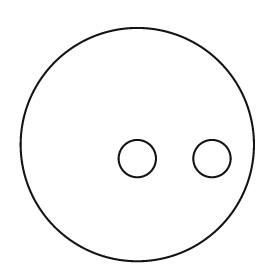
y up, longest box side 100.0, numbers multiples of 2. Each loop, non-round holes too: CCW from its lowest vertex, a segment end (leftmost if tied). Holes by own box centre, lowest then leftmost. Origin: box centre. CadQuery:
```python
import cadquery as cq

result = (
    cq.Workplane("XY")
    .moveTo(0.0, 0.0)
    .circle(50.0)
    .moveTo(0.0, -6.0)
    .circle(8.0)
    .moveTo(32.0, -6.0)
    .circle(8.0)
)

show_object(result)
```